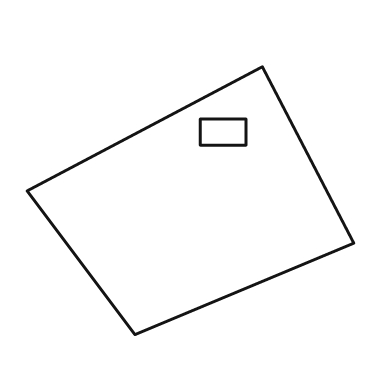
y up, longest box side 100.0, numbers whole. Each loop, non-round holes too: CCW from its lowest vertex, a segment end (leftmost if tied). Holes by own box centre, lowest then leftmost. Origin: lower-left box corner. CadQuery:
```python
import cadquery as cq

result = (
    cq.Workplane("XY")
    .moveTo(33.0, 0.0)
    .lineTo(100.0, 28.0)
    .lineTo(72.0, 82.0)
    .lineTo(0.0, 44.0)
    .close()
    .moveTo(53.0, 58.0)
    .lineTo(67.0, 58.0)
    .lineTo(67.0, 66.0)
    .lineTo(53.0, 66.0)
    .close()
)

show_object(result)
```